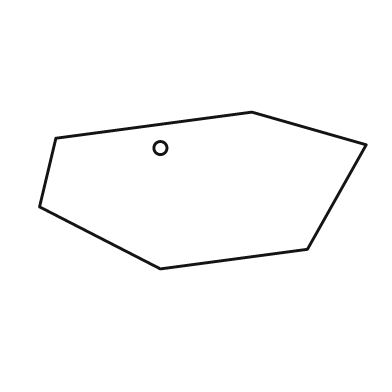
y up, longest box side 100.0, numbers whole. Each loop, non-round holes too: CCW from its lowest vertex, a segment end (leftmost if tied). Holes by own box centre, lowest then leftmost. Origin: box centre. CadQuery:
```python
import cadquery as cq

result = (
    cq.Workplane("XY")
    .moveTo(-13.0, -24.0)
    .lineTo(32.0, -18.0)
    .lineTo(50.0, 14.0)
    .lineTo(15.0, 24.0)
    .lineTo(-45.0, 16.0)
    .lineTo(-50.0, -5.0)
    .close()
    .moveTo(-13.0, 13.0)
    .circle(2.0)
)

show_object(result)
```